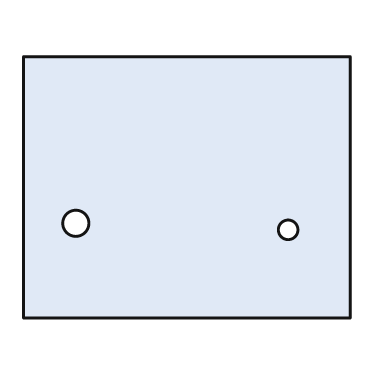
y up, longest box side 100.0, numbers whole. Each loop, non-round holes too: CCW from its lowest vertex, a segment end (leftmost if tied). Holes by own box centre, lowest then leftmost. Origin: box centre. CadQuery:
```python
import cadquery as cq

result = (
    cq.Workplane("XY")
    .moveTo(-50.0, -40.0)
    .lineTo(50.0, -40.0)
    .lineTo(50.0, 40.0)
    .lineTo(-50.0, 40.0)
    .close()
    .moveTo(31.0, -13.0)
    .circle(3.0)
    .moveTo(-34.0, -11.0)
    .circle(4.0)
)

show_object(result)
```